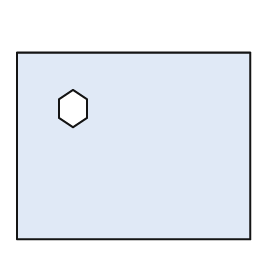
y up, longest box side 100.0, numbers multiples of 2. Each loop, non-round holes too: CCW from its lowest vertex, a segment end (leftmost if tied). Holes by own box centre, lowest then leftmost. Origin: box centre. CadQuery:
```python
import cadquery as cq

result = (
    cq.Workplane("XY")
    .moveTo(-50.0, -40.0)
    .lineTo(50.0, -40.0)
    .lineTo(50.0, 40.0)
    .lineTo(-50.0, 40.0)
    .close()
    .moveTo(-26.0, 8.0)
    .lineTo(-20.0, 12.0)
    .lineTo(-20.0, 20.0)
    .lineTo(-26.0, 24.0)
    .lineTo(-32.0, 20.0)
    .lineTo(-32.0, 12.0)
    .close()
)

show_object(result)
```